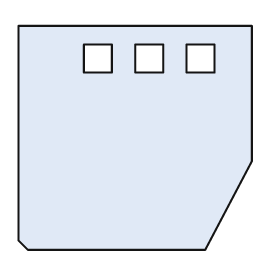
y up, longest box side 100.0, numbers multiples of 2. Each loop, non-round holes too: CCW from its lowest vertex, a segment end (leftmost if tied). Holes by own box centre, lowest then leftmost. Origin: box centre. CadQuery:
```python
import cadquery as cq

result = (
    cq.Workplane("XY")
    .moveTo(-46.0, -48.0)
    .lineTo(30.0, -48.0)
    .lineTo(50.0, -10.0)
    .lineTo(50.0, 48.0)
    .lineTo(-50.0, 48.0)
    .lineTo(-50.0, -44.0)
    .close()
    .moveTo(-22.0, 28.0)
    .lineTo(-10.0, 28.0)
    .lineTo(-10.0, 40.0)
    .lineTo(-22.0, 40.0)
    .close()
    .moveTo(0.0, 28.0)
    .lineTo(12.0, 28.0)
    .lineTo(12.0, 40.0)
    .lineTo(0.0, 40.0)
    .close()
    .moveTo(22.0, 28.0)
    .lineTo(34.0, 28.0)
    .lineTo(34.0, 40.0)
    .lineTo(22.0, 40.0)
    .close()
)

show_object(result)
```